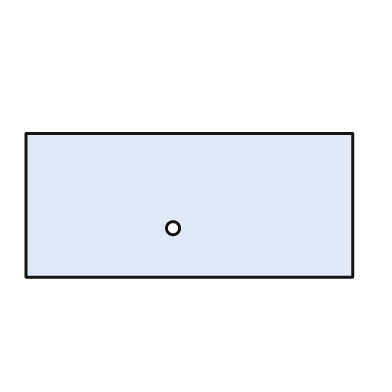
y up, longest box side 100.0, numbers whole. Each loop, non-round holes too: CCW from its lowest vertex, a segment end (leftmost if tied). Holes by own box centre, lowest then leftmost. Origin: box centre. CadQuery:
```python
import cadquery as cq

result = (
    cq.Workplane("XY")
    .moveTo(-50.0, -22.0)
    .lineTo(50.0, -22.0)
    .lineTo(50.0, 22.0)
    .lineTo(-50.0, 22.0)
    .close()
    .moveTo(-5.0, -7.0)
    .circle(2.0)
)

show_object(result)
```